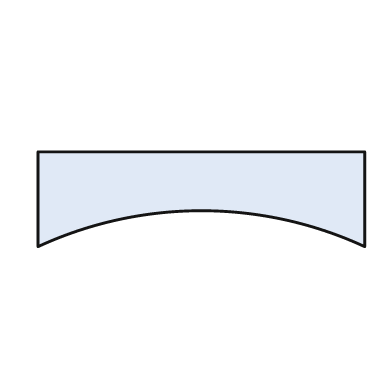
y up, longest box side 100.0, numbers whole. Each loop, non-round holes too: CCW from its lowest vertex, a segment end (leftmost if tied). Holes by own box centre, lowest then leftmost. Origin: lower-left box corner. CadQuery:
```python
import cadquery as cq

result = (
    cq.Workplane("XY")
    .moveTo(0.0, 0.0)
    .threePointArc((50.0, 11.0), (100.0, 0.0))
    .lineTo(100.0, 29.0)
    .lineTo(0.0, 29.0)
    .close()
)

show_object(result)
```